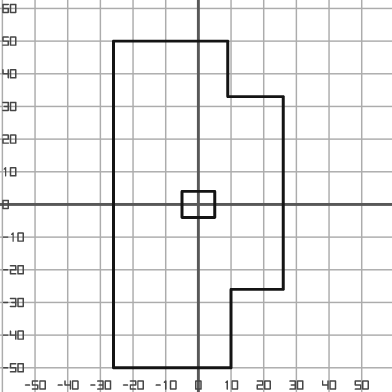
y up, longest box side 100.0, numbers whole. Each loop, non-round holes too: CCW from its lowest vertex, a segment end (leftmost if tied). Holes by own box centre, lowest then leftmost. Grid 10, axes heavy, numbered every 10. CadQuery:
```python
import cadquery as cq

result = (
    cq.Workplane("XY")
    .moveTo(-26.0, -50.0)
    .lineTo(10.0, -50.0)
    .lineTo(10.0, -26.0)
    .lineTo(26.0, -26.0)
    .lineTo(26.0, 33.0)
    .lineTo(9.0, 33.0)
    .lineTo(9.0, 50.0)
    .lineTo(-26.0, 50.0)
    .close()
    .moveTo(-5.0, -4.0)
    .lineTo(5.0, -4.0)
    .lineTo(5.0, 4.0)
    .lineTo(-5.0, 4.0)
    .close()
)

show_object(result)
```